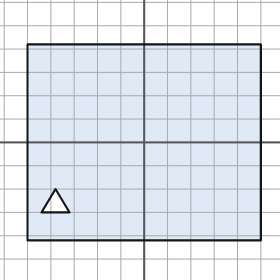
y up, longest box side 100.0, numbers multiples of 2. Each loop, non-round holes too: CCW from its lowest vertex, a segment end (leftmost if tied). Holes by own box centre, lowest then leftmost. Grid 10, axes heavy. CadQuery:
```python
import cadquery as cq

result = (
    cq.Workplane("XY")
    .moveTo(-50.0, -42.0)
    .lineTo(50.0, -42.0)
    .lineTo(50.0, 42.0)
    .lineTo(-50.0, 42.0)
    .close()
    .moveTo(-44.0, -30.0)
    .lineTo(-32.0, -30.0)
    .lineTo(-38.0, -20.0)
    .close()
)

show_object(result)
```